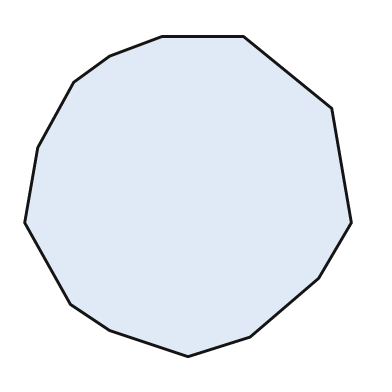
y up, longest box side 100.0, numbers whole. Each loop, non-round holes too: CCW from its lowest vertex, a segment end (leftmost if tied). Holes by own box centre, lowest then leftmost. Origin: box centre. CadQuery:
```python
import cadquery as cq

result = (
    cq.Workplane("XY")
    .moveTo(0.0, -49.0)
    .lineTo(19.0, -43.0)
    .lineTo(40.0, -25.0)
    .lineTo(50.0, -8.0)
    .lineTo(44.0, 27.0)
    .lineTo(17.0, 49.0)
    .lineTo(-8.0, 49.0)
    .lineTo(-24.0, 43.0)
    .lineTo(-35.0, 35.0)
    .lineTo(-46.0, 15.0)
    .lineTo(-50.0, -8.0)
    .lineTo(-36.0, -33.0)
    .lineTo(-24.0, -41.0)
    .close()
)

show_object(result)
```